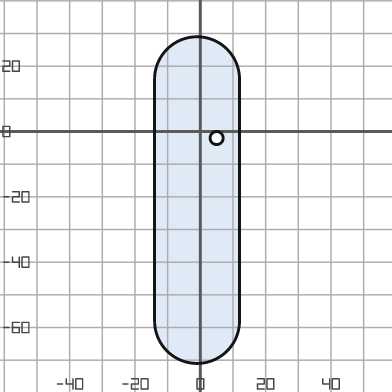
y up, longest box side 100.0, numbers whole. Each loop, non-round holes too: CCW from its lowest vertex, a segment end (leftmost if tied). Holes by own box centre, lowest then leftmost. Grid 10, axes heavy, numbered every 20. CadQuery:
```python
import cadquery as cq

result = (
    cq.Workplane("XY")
    .moveTo(-14.0, -58.0)
    .threePointArc((-1.0, -71.0), (12.0, -58.0))
    .lineTo(12.0, 16.0)
    .threePointArc((-1.0, 29.0), (-14.0, 16.0))
    .close()
    .moveTo(5.0, -2.0)
    .circle(2.0)
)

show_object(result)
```